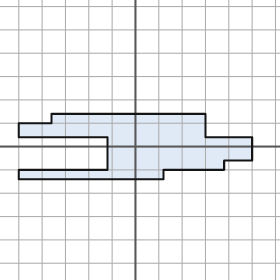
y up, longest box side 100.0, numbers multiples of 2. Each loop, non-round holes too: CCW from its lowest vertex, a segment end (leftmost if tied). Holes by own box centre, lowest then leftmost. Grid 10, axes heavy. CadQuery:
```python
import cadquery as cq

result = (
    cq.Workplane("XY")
    .moveTo(-50.0, -14.0)
    .lineTo(12.0, -14.0)
    .lineTo(12.0, -10.0)
    .lineTo(38.0, -10.0)
    .lineTo(38.0, -6.0)
    .lineTo(50.0, -6.0)
    .lineTo(50.0, 4.0)
    .lineTo(30.0, 4.0)
    .lineTo(30.0, 14.0)
    .lineTo(-36.0, 14.0)
    .lineTo(-36.0, 10.0)
    .lineTo(-50.0, 10.0)
    .lineTo(-50.0, 4.0)
    .lineTo(-12.0, 4.0)
    .lineTo(-12.0, -10.0)
    .lineTo(-50.0, -10.0)
    .close()
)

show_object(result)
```